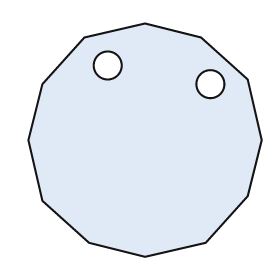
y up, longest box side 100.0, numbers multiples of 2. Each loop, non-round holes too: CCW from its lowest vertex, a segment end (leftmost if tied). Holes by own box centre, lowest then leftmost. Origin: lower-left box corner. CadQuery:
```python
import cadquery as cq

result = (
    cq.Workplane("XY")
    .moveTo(50.0, 0.0)
    .lineTo(76.0, 6.0)
    .lineTo(94.0, 26.0)
    .lineTo(100.0, 50.0)
    .lineTo(94.0, 76.0)
    .lineTo(74.0, 94.0)
    .lineTo(50.0, 100.0)
    .lineTo(24.0, 94.0)
    .lineTo(6.0, 74.0)
    .lineTo(0.0, 50.0)
    .lineTo(6.0, 24.0)
    .lineTo(26.0, 6.0)
    .close()
    .moveTo(78.0, 74.0)
    .circle(6.0)
    .moveTo(34.0, 82.0)
    .circle(6.0)
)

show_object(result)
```